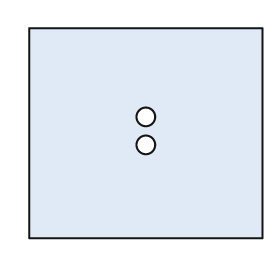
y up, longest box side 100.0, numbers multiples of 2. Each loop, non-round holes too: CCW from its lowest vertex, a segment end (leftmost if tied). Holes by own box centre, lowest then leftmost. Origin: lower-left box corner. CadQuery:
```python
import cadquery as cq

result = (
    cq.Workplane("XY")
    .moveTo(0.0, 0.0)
    .lineTo(100.0, 0.0)
    .lineTo(100.0, 90.0)
    .lineTo(0.0, 90.0)
    .close()
    .moveTo(50.0, 40.0)
    .circle(4.0)
    .moveTo(50.0, 52.0)
    .circle(4.0)
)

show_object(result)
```